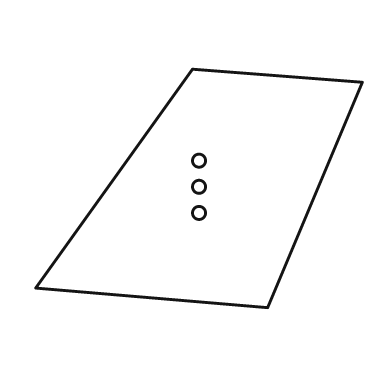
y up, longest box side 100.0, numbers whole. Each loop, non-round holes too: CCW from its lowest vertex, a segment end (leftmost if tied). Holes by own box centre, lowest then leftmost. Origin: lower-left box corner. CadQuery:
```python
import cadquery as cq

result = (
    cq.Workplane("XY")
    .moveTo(71.0, 0.0)
    .lineTo(100.0, 69.0)
    .lineTo(48.0, 73.0)
    .lineTo(0.0, 6.0)
    .close()
    .moveTo(50.0, 29.0)
    .circle(2.0)
    .moveTo(50.0, 37.0)
    .circle(2.0)
    .moveTo(50.0, 45.0)
    .circle(2.0)
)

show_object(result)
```